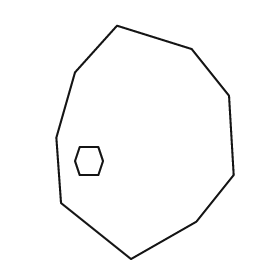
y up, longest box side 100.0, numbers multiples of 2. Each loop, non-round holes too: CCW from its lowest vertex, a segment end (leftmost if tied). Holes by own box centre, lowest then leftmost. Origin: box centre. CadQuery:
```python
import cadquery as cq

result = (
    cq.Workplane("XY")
    .moveTo(-6.0, -50.0)
    .lineTo(22.0, -34.0)
    .lineTo(38.0, -14.0)
    .lineTo(36.0, 20.0)
    .lineTo(20.0, 40.0)
    .lineTo(-12.0, 50.0)
    .lineTo(-30.0, 30.0)
    .lineTo(-38.0, 2.0)
    .lineTo(-36.0, -26.0)
    .close()
    .moveTo(-28.0, -14.0)
    .lineTo(-20.0, -14.0)
    .lineTo(-18.0, -8.0)
    .lineTo(-20.0, -2.0)
    .lineTo(-28.0, -2.0)
    .lineTo(-30.0, -8.0)
    .close()
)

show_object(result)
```